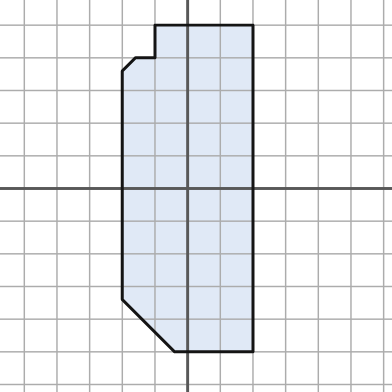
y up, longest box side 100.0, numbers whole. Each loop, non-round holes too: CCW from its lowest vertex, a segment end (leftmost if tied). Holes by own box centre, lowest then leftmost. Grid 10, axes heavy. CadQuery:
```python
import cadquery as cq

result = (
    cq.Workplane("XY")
    .moveTo(-4.0, -50.0)
    .lineTo(20.0, -50.0)
    .lineTo(20.0, 50.0)
    .lineTo(-10.0, 50.0)
    .lineTo(-10.0, 40.0)
    .lineTo(-16.0, 40.0)
    .lineTo(-20.0, 36.0)
    .lineTo(-20.0, -34.0)
    .close()
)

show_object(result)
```